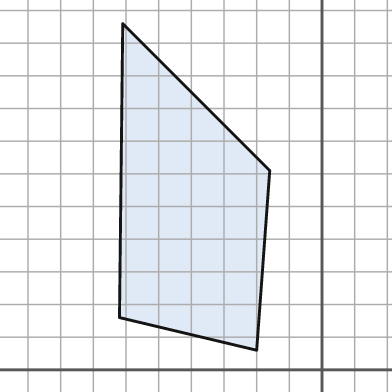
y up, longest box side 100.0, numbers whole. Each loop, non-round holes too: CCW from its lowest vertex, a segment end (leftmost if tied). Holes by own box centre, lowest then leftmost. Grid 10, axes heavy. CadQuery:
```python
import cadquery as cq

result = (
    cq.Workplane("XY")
    .moveTo(-20.0, 6.0)
    .lineTo(-16.0, 61.0)
    .lineTo(-61.0, 106.0)
    .lineTo(-62.0, 16.0)
    .close()
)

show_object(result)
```